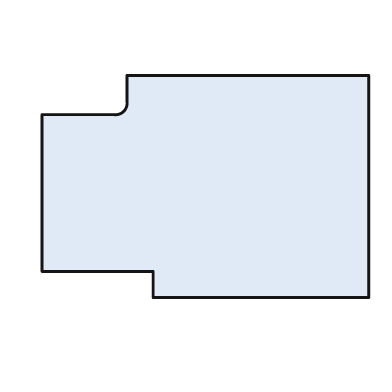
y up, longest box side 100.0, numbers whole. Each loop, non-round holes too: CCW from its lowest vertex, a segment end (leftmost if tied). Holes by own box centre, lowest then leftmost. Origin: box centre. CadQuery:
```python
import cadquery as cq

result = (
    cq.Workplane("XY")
    .moveTo(-16.0, -34.0)
    .lineTo(50.0, -34.0)
    .lineTo(50.0, 34.0)
    .lineTo(-24.0, 34.0)
    .lineTo(-24.0, 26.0)
    .threePointArc((-25.0, 23.0), (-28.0, 22.0))
    .lineTo(-50.0, 22.0)
    .lineTo(-50.0, -26.0)
    .lineTo(-16.0, -26.0)
    .close()
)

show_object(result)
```